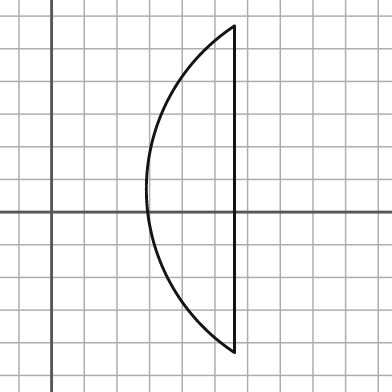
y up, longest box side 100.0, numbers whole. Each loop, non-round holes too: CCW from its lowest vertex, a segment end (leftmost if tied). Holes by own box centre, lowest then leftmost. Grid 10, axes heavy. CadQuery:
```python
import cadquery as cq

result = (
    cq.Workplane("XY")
    .moveTo(56.0, -43.0)
    .lineTo(56.0, 57.0)
    .threePointArc((29.0, 7.0), (56.0, -43.0))
    .close()
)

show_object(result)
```